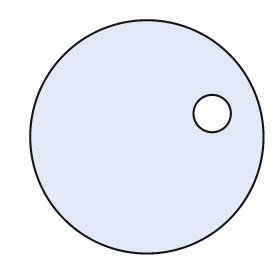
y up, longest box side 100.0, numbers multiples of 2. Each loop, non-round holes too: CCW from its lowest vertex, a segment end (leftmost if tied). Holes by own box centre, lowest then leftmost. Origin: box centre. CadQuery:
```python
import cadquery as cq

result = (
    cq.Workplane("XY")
    .moveTo(0.0, 0.0)
    .circle(50.0)
    .moveTo(28.0, 10.0)
    .circle(8.0)
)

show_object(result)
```